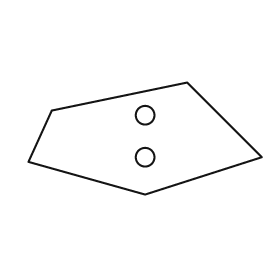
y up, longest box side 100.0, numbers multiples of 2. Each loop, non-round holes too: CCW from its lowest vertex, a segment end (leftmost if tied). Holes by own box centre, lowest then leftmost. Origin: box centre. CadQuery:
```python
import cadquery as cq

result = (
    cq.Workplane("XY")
    .moveTo(0.0, -24.0)
    .lineTo(50.0, -8.0)
    .lineTo(18.0, 24.0)
    .lineTo(-40.0, 12.0)
    .lineTo(-50.0, -10.0)
    .close()
    .moveTo(0.0, -8.0)
    .circle(4.0)
    .moveTo(0.0, 10.0)
    .circle(4.0)
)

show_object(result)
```